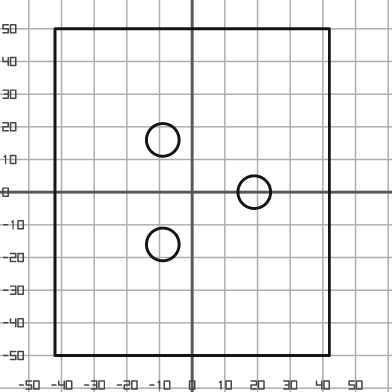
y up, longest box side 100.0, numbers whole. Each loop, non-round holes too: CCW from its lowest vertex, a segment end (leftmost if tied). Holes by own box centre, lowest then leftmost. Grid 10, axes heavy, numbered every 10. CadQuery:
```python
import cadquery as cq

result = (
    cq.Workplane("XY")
    .moveTo(-42.0, -50.0)
    .lineTo(42.0, -50.0)
    .lineTo(42.0, 50.0)
    .lineTo(-42.0, 50.0)
    .close()
    .moveTo(-9.0, -16.0)
    .circle(5.0)
    .moveTo(19.0, 0.0)
    .circle(5.0)
    .moveTo(-9.0, 16.0)
    .circle(5.0)
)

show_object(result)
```